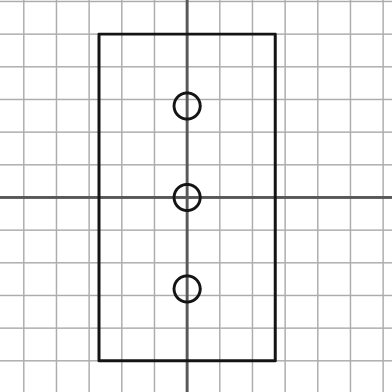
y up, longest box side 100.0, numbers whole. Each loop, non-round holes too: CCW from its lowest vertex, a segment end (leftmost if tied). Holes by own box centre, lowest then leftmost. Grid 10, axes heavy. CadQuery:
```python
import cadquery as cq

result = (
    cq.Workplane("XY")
    .moveTo(-27.0, -50.0)
    .lineTo(27.0, -50.0)
    .lineTo(27.0, 50.0)
    .lineTo(-27.0, 50.0)
    .close()
    .moveTo(0.0, -28.0)
    .circle(4.0)
    .moveTo(0.0, 0.0)
    .circle(4.0)
    .moveTo(0.0, 28.0)
    .circle(4.0)
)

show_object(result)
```